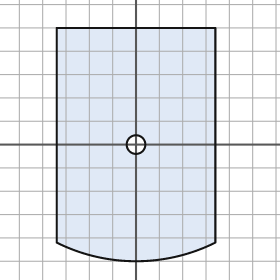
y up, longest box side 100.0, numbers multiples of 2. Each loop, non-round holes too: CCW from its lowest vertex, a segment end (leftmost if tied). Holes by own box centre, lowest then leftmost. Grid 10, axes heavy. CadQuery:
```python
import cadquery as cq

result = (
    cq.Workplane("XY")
    .moveTo(-34.0, -42.0)
    .threePointArc((0.0, -50.0), (34.0, -42.0))
    .lineTo(34.0, 50.0)
    .lineTo(-34.0, 50.0)
    .close()
    .moveTo(0.0, 0.0)
    .circle(4.0)
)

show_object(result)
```